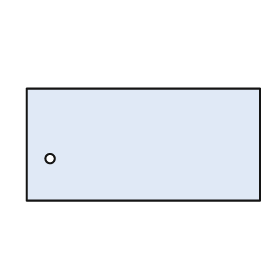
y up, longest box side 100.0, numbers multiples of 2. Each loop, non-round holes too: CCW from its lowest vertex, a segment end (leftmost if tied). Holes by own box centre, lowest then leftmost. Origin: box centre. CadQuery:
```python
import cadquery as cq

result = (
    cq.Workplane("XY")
    .moveTo(-50.0, -24.0)
    .lineTo(50.0, -24.0)
    .lineTo(50.0, 24.0)
    .lineTo(-50.0, 24.0)
    .close()
    .moveTo(-40.0, -6.0)
    .circle(2.0)
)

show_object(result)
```